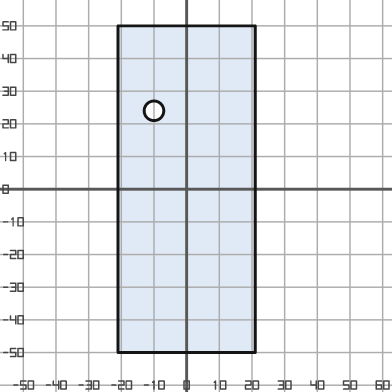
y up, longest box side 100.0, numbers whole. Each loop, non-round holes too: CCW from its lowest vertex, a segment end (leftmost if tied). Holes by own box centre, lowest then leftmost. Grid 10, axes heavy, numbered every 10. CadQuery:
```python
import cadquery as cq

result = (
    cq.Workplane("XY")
    .moveTo(-21.0, -50.0)
    .lineTo(21.0, -50.0)
    .lineTo(21.0, 50.0)
    .lineTo(-21.0, 50.0)
    .close()
    .moveTo(-10.0, 24.0)
    .circle(3.0)
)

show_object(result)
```